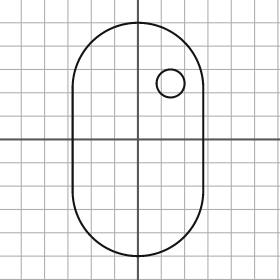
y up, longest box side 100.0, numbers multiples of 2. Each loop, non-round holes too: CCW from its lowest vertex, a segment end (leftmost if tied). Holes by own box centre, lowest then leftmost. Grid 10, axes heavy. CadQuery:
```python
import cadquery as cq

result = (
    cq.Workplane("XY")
    .moveTo(-28.0, -22.0)
    .threePointArc((0.0, -50.0), (28.0, -22.0))
    .lineTo(28.0, 22.0)
    .threePointArc((0.0, 50.0), (-28.0, 22.0))
    .close()
    .moveTo(14.0, 24.0)
    .circle(6.0)
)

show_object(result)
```